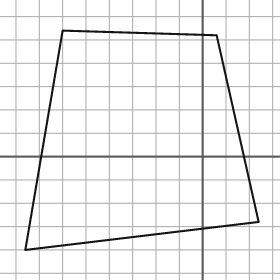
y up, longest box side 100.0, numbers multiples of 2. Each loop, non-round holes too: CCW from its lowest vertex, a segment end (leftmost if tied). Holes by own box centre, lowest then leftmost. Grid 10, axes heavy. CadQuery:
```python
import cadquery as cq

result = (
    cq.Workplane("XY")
    .moveTo(-76.0, -40.0)
    .lineTo(24.0, -28.0)
    .lineTo(6.0, 52.0)
    .lineTo(-60.0, 54.0)
    .close()
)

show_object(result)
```